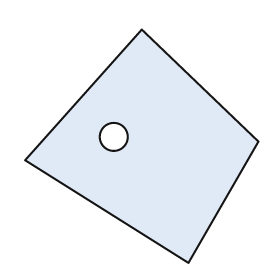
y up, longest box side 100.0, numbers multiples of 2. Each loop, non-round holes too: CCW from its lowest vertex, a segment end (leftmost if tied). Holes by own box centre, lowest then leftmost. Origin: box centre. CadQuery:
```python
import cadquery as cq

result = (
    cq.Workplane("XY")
    .moveTo(20.0, -50.0)
    .lineTo(50.0, 2.0)
    .lineTo(0.0, 50.0)
    .lineTo(-50.0, -6.0)
    .close()
    .moveTo(-12.0, 4.0)
    .circle(6.0)
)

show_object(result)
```